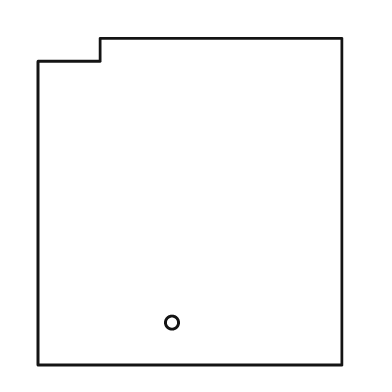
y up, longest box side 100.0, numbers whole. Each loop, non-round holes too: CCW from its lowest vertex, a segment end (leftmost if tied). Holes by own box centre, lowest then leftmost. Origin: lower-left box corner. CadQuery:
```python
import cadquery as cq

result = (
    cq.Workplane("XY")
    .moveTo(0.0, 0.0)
    .lineTo(93.0, 0.0)
    .lineTo(93.0, 100.0)
    .lineTo(19.0, 100.0)
    .lineTo(19.0, 93.0)
    .lineTo(0.0, 93.0)
    .close()
    .moveTo(41.0, 13.0)
    .circle(2.0)
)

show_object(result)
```